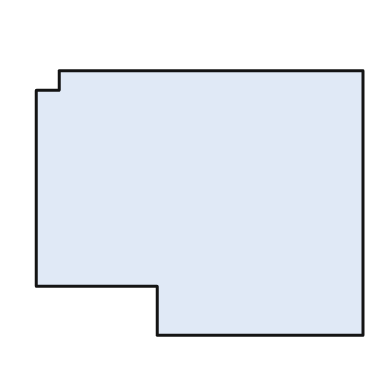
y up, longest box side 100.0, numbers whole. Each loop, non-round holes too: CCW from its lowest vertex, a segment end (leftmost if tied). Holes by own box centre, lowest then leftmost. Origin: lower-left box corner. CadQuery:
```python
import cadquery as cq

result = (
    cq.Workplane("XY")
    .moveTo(37.0, 0.0)
    .lineTo(100.0, 0.0)
    .lineTo(100.0, 81.0)
    .lineTo(7.0, 81.0)
    .lineTo(7.0, 75.0)
    .lineTo(0.0, 75.0)
    .lineTo(0.0, 15.0)
    .lineTo(37.0, 15.0)
    .close()
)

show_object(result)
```